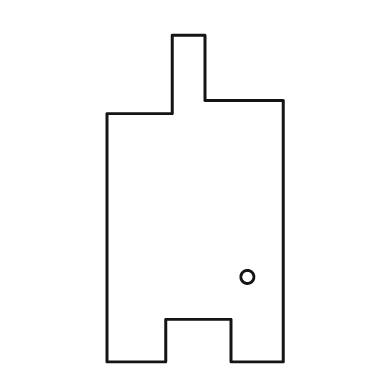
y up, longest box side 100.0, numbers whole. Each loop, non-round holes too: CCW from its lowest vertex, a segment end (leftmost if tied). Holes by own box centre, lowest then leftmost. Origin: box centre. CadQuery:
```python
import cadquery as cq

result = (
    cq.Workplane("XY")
    .moveTo(-27.0, -50.0)
    .lineTo(-9.0, -50.0)
    .lineTo(-9.0, -37.0)
    .lineTo(11.0, -37.0)
    .lineTo(11.0, -50.0)
    .lineTo(27.0, -50.0)
    .lineTo(27.0, 30.0)
    .lineTo(3.0, 30.0)
    .lineTo(3.0, 50.0)
    .lineTo(-7.0, 50.0)
    .lineTo(-7.0, 26.0)
    .lineTo(-27.0, 26.0)
    .close()
    .moveTo(16.0, -24.0)
    .circle(2.0)
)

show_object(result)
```